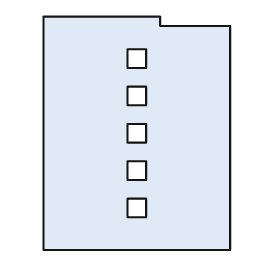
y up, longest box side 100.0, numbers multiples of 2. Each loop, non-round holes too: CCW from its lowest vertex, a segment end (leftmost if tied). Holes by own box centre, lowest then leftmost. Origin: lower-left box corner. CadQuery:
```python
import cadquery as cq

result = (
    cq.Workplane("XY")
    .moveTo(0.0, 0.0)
    .lineTo(80.0, 0.0)
    .lineTo(80.0, 96.0)
    .lineTo(50.0, 96.0)
    .lineTo(50.0, 100.0)
    .lineTo(0.0, 100.0)
    .close()
    .moveTo(36.0, 14.0)
    .lineTo(44.0, 14.0)
    .lineTo(44.0, 22.0)
    .lineTo(36.0, 22.0)
    .close()
    .moveTo(36.0, 30.0)
    .lineTo(44.0, 30.0)
    .lineTo(44.0, 38.0)
    .lineTo(36.0, 38.0)
    .close()
    .moveTo(36.0, 46.0)
    .lineTo(44.0, 46.0)
    .lineTo(44.0, 54.0)
    .lineTo(36.0, 54.0)
    .close()
    .moveTo(36.0, 62.0)
    .lineTo(44.0, 62.0)
    .lineTo(44.0, 70.0)
    .lineTo(36.0, 70.0)
    .close()
    .moveTo(36.0, 78.0)
    .lineTo(44.0, 78.0)
    .lineTo(44.0, 86.0)
    .lineTo(36.0, 86.0)
    .close()
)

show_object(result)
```